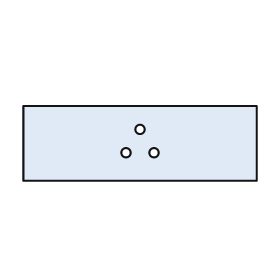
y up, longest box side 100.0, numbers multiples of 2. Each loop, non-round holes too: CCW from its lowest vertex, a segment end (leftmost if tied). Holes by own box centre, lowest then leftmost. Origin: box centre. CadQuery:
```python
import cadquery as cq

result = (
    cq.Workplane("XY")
    .moveTo(-50.0, -16.0)
    .lineTo(50.0, -16.0)
    .lineTo(50.0, 16.0)
    .lineTo(-50.0, 16.0)
    .close()
    .moveTo(-6.0, -4.0)
    .circle(2.0)
    .moveTo(6.0, -4.0)
    .circle(2.0)
    .moveTo(0.0, 6.0)
    .circle(2.0)
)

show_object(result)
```